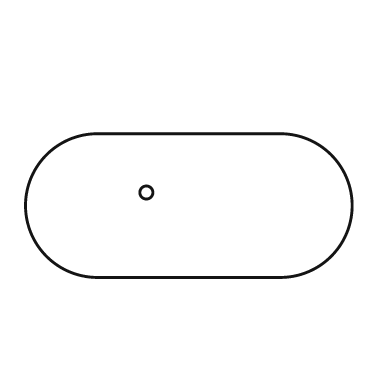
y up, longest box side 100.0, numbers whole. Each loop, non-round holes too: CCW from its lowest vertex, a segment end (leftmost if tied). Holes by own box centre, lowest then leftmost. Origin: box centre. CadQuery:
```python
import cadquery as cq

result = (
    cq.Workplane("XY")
    .moveTo(-28.0, -22.0)
    .lineTo(28.0, -22.0)
    .threePointArc((50.0, 0.0), (28.0, 22.0))
    .lineTo(-28.0, 22.0)
    .threePointArc((-50.0, 0.0), (-28.0, -22.0))
    .close()
    .moveTo(-13.0, 4.0)
    .circle(2.0)
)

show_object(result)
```